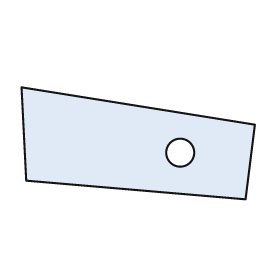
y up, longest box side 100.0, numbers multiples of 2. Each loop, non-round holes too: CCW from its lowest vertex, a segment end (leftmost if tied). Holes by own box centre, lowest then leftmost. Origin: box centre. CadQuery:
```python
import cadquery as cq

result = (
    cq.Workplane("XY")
    .moveTo(46.0, -24.0)
    .lineTo(50.0, 8.0)
    .lineTo(-50.0, 24.0)
    .lineTo(-48.0, -16.0)
    .close()
    .moveTo(18.0, -4.0)
    .circle(6.0)
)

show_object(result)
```